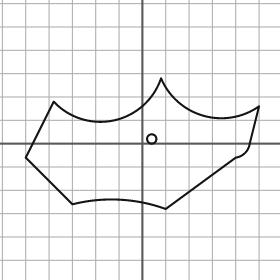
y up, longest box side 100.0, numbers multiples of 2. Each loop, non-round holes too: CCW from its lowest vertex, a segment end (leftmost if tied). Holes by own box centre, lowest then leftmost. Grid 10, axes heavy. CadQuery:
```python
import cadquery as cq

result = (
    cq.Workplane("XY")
    .moveTo(10.0, -28.0)
    .lineTo(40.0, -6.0)
    .threePointArc((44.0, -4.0), (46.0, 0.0))
    .lineTo(50.0, 16.0)
    .threePointArc((26.0, 12.0), (8.0, 28.0))
    .threePointArc((-12.0, 10.0), (-38.0, 18.0))
    .lineTo(-50.0, -6.0)
    .lineTo(-30.0, -26.0)
    .threePointArc((-10.0, -24.0), (10.0, -28.0))
    .close()
    .moveTo(4.0, 2.0)
    .circle(2.0)
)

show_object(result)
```